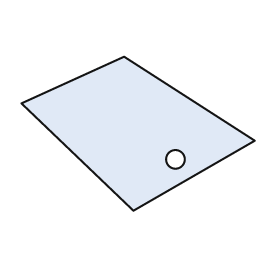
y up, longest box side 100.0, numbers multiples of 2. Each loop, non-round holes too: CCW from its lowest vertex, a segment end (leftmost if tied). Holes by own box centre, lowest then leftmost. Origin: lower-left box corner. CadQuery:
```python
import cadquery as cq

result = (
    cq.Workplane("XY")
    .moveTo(48.0, 0.0)
    .lineTo(100.0, 30.0)
    .lineTo(44.0, 66.0)
    .lineTo(0.0, 46.0)
    .close()
    .moveTo(66.0, 22.0)
    .circle(4.0)
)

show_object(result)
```